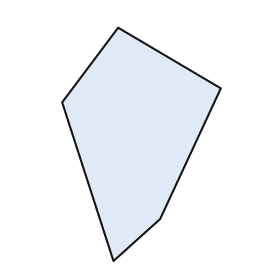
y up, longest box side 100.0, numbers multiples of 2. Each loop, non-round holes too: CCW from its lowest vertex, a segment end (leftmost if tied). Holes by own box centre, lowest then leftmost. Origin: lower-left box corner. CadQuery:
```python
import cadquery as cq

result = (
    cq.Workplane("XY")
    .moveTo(22.0, 0.0)
    .lineTo(42.0, 18.0)
    .lineTo(68.0, 74.0)
    .lineTo(24.0, 100.0)
    .lineTo(0.0, 68.0)
    .close()
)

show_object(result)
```